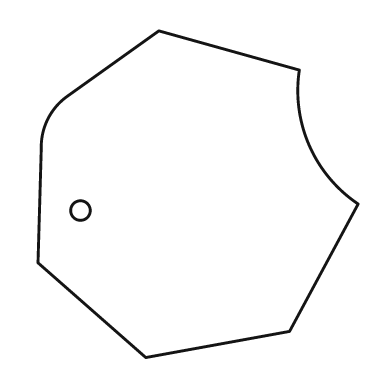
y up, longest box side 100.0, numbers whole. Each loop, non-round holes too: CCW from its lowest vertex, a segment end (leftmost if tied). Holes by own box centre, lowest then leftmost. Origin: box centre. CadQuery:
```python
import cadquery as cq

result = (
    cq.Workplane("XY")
    .moveTo(-16.0, -50.0)
    .lineTo(28.0, -42.0)
    .lineTo(49.0, -3.0)
    .threePointArc((34.0, 15.0), (31.0, 38.0))
    .lineTo(-12.0, 50.0)
    .lineTo(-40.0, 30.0)
    .threePointArc((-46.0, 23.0), (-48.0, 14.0))
    .lineTo(-49.0, -21.0)
    .close()
    .moveTo(-36.0, -5.0)
    .circle(3.0)
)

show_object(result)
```